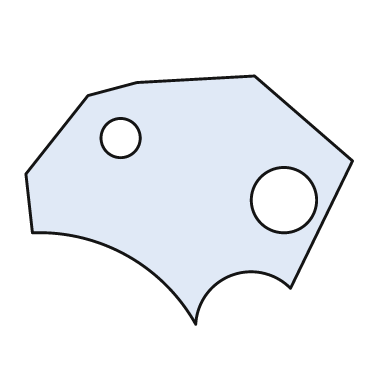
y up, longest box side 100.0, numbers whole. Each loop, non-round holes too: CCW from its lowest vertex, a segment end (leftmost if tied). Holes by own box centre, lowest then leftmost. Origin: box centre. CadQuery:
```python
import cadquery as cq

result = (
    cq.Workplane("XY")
    .moveTo(2.0, -38.0)
    .threePointArc((13.0, -23.0), (31.0, -27.0))
    .lineTo(50.0, 12.0)
    .lineTo(20.0, 38.0)
    .lineTo(-16.0, 36.0)
    .lineTo(-31.0, 32.0)
    .lineTo(-50.0, 8.0)
    .lineTo(-48.0, -10.0)
    .threePointArc((-19.0, -17.0), (2.0, -38.0))
    .close()
    .moveTo(29.0, 0.0)
    .circle(10.0)
    .moveTo(-21.0, 19.0)
    .circle(6.0)
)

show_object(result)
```